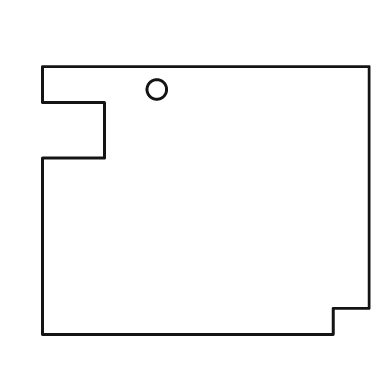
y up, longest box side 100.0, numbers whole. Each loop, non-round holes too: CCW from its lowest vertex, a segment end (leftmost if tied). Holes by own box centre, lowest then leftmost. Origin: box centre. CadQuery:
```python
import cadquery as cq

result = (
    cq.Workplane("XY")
    .moveTo(-50.0, -41.0)
    .lineTo(39.0, -41.0)
    .lineTo(39.0, -33.0)
    .lineTo(50.0, -33.0)
    .lineTo(50.0, 41.0)
    .lineTo(-50.0, 41.0)
    .lineTo(-50.0, 30.0)
    .lineTo(-31.0, 30.0)
    .lineTo(-31.0, 13.0)
    .lineTo(-50.0, 13.0)
    .close()
    .moveTo(-15.0, 34.0)
    .circle(3.0)
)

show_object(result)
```